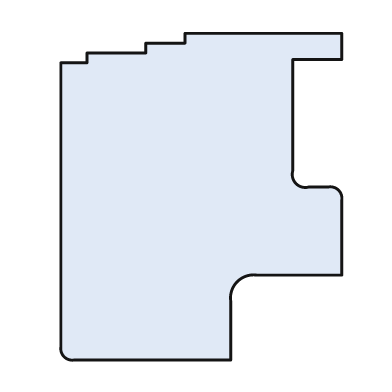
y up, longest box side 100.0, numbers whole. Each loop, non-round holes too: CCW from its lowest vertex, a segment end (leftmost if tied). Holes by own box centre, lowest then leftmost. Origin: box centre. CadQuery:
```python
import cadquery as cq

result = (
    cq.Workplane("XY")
    .moveTo(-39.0, -50.0)
    .lineTo(9.0, -50.0)
    .lineTo(9.0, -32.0)
    .threePointArc((11.0, -26.0), (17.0, -24.0))
    .lineTo(43.0, -24.0)
    .lineTo(43.0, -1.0)
    .threePointArc((42.0, 2.0), (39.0, 3.0))
    .lineTo(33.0, 3.0)
    .threePointArc((29.0, 4.0), (28.0, 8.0))
    .lineTo(28.0, 42.0)
    .lineTo(43.0, 42.0)
    .lineTo(43.0, 50.0)
    .lineTo(-5.0, 50.0)
    .lineTo(-5.0, 47.0)
    .lineTo(-17.0, 47.0)
    .lineTo(-17.0, 44.0)
    .lineTo(-35.0, 44.0)
    .lineTo(-35.0, 41.0)
    .lineTo(-43.0, 41.0)
    .lineTo(-43.0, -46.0)
    .threePointArc((-42.0, -49.0), (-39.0, -50.0))
    .close()
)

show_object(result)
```